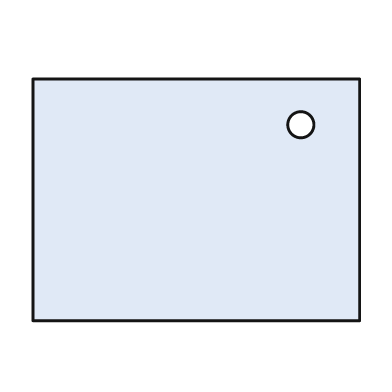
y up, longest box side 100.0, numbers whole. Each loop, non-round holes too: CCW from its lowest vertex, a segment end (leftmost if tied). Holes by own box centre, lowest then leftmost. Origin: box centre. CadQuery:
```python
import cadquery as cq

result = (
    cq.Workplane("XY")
    .moveTo(-50.0, -37.0)
    .lineTo(50.0, -37.0)
    .lineTo(50.0, 37.0)
    .lineTo(-50.0, 37.0)
    .close()
    .moveTo(32.0, 23.0)
    .circle(4.0)
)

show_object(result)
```